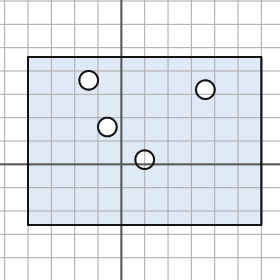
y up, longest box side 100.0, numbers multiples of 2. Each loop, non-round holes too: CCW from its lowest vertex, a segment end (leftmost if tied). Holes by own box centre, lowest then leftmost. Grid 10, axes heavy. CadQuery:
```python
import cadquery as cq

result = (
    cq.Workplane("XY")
    .moveTo(-40.0, -26.0)
    .lineTo(60.0, -26.0)
    .lineTo(60.0, 46.0)
    .lineTo(-40.0, 46.0)
    .close()
    .moveTo(10.0, 2.0)
    .circle(4.0)
    .moveTo(-6.0, 16.0)
    .circle(4.0)
    .moveTo(36.0, 32.0)
    .circle(4.0)
    .moveTo(-14.0, 36.0)
    .circle(4.0)
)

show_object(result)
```